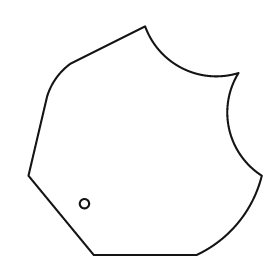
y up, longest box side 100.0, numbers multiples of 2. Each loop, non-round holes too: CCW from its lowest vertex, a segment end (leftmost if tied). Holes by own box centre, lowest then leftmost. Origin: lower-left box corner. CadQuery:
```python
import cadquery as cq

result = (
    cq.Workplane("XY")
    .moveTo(28.0, 0.0)
    .lineTo(72.0, 0.0)
    .threePointArc((90.0, 14.0), (100.0, 34.0))
    .threePointArc((86.0, 54.0), (90.0, 78.0))
    .threePointArc((66.0, 80.0), (50.0, 98.0))
    .lineTo(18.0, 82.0)
    .threePointArc((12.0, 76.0), (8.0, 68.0))
    .lineTo(0.0, 34.0)
    .close()
    .moveTo(24.0, 22.0)
    .circle(2.0)
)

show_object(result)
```